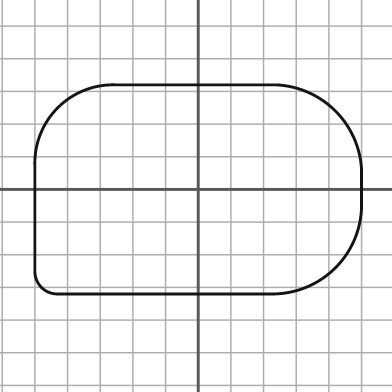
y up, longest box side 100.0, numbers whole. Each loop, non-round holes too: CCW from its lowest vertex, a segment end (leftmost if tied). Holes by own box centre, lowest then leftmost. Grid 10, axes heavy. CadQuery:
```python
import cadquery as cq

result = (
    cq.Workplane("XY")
    .moveTo(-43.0, -32.0)
    .lineTo(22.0, -32.0)
    .threePointArc((42.0, -24.0), (50.0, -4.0))
    .lineTo(50.0, 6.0)
    .threePointArc((42.0, 24.0), (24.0, 32.0))
    .lineTo(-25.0, 32.0)
    .threePointArc((-43.0, 25.0), (-50.0, 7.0))
    .lineTo(-50.0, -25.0)
    .threePointArc((-48.0, -30.0), (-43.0, -32.0))
    .close()
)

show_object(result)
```